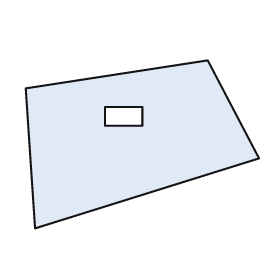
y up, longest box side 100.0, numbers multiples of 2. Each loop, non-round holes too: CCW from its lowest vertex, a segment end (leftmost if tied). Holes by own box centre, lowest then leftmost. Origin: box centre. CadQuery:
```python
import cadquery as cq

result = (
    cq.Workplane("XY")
    .moveTo(-46.0, -36.0)
    .lineTo(50.0, -6.0)
    .lineTo(28.0, 36.0)
    .lineTo(-50.0, 24.0)
    .close()
    .moveTo(-16.0, 8.0)
    .lineTo(0.0, 8.0)
    .lineTo(0.0, 16.0)
    .lineTo(-16.0, 16.0)
    .close()
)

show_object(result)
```